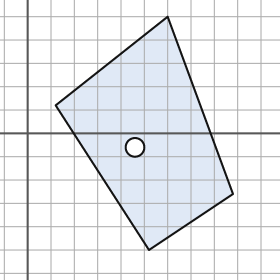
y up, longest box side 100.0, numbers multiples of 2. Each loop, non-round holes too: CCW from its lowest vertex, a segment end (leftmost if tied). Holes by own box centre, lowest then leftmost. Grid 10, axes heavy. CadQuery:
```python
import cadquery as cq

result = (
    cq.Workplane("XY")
    .moveTo(52.0, -50.0)
    .lineTo(88.0, -26.0)
    .lineTo(60.0, 50.0)
    .lineTo(12.0, 12.0)
    .close()
    .moveTo(46.0, -6.0)
    .circle(4.0)
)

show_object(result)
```